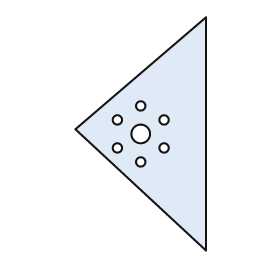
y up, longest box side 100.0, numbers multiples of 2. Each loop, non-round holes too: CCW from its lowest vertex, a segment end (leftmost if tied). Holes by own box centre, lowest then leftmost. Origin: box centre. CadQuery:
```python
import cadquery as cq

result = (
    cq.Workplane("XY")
    .moveTo(28.0, -50.0)
    .lineTo(28.0, 50.0)
    .lineTo(-28.0, 2.0)
    .close()
    .moveTo(0.0, -12.0)
    .circle(2.0)
    .moveTo(-10.0, -6.0)
    .circle(2.0)
    .moveTo(10.0, -6.0)
    .circle(2.0)
    .moveTo(0.0, 0.0)
    .circle(4.0)
    .moveTo(-10.0, 6.0)
    .circle(2.0)
    .moveTo(10.0, 6.0)
    .circle(2.0)
    .moveTo(0.0, 12.0)
    .circle(2.0)
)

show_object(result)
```